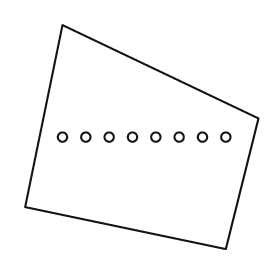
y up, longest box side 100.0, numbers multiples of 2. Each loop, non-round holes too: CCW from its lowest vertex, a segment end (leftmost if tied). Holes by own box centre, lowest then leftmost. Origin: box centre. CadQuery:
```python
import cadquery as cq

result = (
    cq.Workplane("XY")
    .moveTo(36.0, -48.0)
    .lineTo(50.0, 8.0)
    .lineTo(-34.0, 48.0)
    .lineTo(-50.0, -30.0)
    .close()
    .moveTo(-34.0, 0.0)
    .circle(2.0)
    .moveTo(-24.0, 0.0)
    .circle(2.0)
    .moveTo(-14.0, 0.0)
    .circle(2.0)
    .moveTo(-4.0, 0.0)
    .circle(2.0)
    .moveTo(6.0, 0.0)
    .circle(2.0)
    .moveTo(16.0, 0.0)
    .circle(2.0)
    .moveTo(26.0, 0.0)
    .circle(2.0)
    .moveTo(36.0, 0.0)
    .circle(2.0)
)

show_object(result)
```